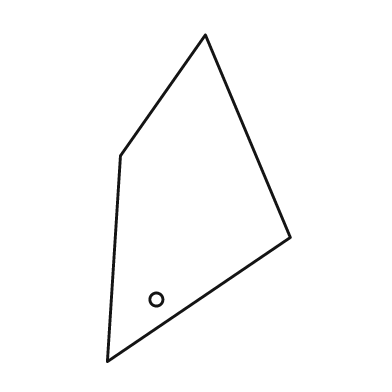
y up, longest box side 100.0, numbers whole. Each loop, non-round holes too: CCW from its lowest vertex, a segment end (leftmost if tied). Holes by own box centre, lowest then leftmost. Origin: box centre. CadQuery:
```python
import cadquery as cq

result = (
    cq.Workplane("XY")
    .moveTo(-28.0, -50.0)
    .lineTo(28.0, -12.0)
    .lineTo(2.0, 50.0)
    .lineTo(-24.0, 13.0)
    .close()
    .moveTo(-13.0, -31.0)
    .circle(2.0)
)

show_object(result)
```